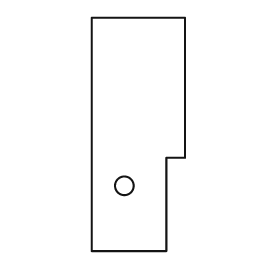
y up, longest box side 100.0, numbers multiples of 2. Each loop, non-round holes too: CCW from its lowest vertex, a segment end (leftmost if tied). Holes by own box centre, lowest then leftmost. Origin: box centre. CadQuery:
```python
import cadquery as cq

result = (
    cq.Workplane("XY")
    .moveTo(-20.0, -50.0)
    .lineTo(12.0, -50.0)
    .lineTo(12.0, -10.0)
    .lineTo(20.0, -10.0)
    .lineTo(20.0, 50.0)
    .lineTo(-20.0, 50.0)
    .close()
    .moveTo(-6.0, -22.0)
    .circle(4.0)
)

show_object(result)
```